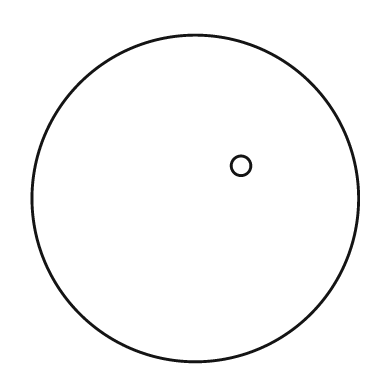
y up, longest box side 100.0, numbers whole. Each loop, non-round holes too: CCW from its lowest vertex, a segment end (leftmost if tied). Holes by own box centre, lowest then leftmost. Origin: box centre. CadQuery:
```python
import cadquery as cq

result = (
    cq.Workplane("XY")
    .moveTo(0.0, 0.0)
    .circle(50.0)
    .moveTo(14.0, 10.0)
    .circle(3.0)
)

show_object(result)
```